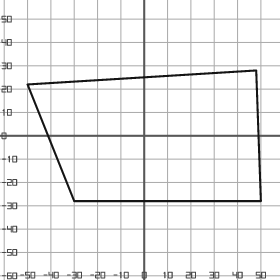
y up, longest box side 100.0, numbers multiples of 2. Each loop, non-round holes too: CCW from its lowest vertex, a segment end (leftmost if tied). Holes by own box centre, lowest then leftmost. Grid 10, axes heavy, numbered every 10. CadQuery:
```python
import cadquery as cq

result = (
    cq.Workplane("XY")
    .moveTo(-30.0, -28.0)
    .lineTo(50.0, -28.0)
    .lineTo(48.0, 28.0)
    .lineTo(-50.0, 22.0)
    .close()
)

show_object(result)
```